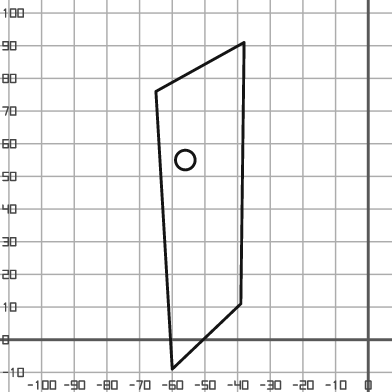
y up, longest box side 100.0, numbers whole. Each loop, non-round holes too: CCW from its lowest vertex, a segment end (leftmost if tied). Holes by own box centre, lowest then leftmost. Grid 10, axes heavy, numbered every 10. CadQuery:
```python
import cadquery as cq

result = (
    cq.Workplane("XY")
    .moveTo(-60.0, -9.0)
    .lineTo(-39.0, 11.0)
    .lineTo(-38.0, 91.0)
    .lineTo(-65.0, 76.0)
    .close()
    .moveTo(-56.0, 55.0)
    .circle(3.0)
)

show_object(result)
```